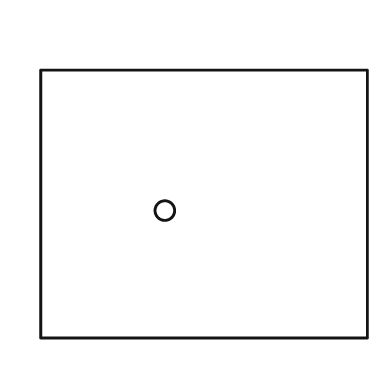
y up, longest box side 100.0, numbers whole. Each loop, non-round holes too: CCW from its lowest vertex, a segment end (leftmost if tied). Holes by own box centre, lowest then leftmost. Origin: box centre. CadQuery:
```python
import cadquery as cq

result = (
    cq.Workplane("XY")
    .moveTo(-50.0, -41.0)
    .lineTo(50.0, -41.0)
    .lineTo(50.0, 41.0)
    .lineTo(-50.0, 41.0)
    .close()
    .moveTo(-12.0, -2.0)
    .circle(3.0)
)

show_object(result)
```